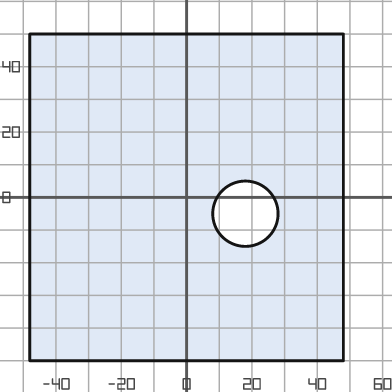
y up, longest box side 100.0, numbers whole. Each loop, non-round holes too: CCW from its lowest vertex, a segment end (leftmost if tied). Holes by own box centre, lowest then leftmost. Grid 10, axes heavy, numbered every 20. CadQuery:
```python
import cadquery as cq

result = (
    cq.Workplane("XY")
    .moveTo(-48.0, -50.0)
    .lineTo(48.0, -50.0)
    .lineTo(48.0, 50.0)
    .lineTo(-48.0, 50.0)
    .close()
    .moveTo(18.0, -5.0)
    .circle(10.0)
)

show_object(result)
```